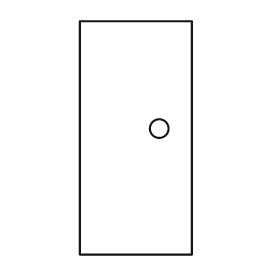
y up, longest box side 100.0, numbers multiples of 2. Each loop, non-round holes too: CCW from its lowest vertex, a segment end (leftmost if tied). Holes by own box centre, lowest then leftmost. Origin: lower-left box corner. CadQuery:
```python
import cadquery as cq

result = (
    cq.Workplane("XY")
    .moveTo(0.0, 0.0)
    .lineTo(48.0, 0.0)
    .lineTo(48.0, 100.0)
    .lineTo(0.0, 100.0)
    .close()
    .moveTo(34.0, 54.0)
    .circle(4.0)
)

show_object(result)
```